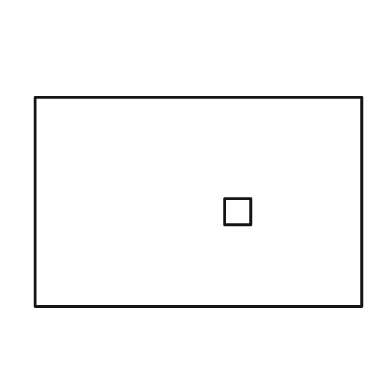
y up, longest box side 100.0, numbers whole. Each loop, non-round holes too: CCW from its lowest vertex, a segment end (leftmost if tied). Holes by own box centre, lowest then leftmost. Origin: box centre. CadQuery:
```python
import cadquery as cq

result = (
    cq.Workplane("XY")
    .moveTo(-50.0, -32.0)
    .lineTo(50.0, -32.0)
    .lineTo(50.0, 32.0)
    .lineTo(-50.0, 32.0)
    .close()
    .moveTo(8.0, -7.0)
    .lineTo(16.0, -7.0)
    .lineTo(16.0, 1.0)
    .lineTo(8.0, 1.0)
    .close()
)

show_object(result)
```